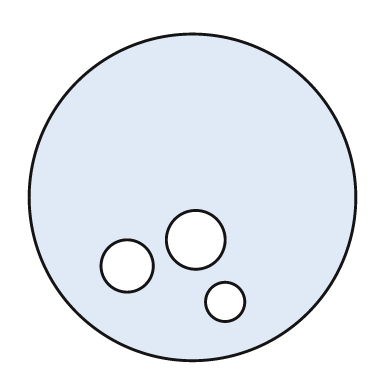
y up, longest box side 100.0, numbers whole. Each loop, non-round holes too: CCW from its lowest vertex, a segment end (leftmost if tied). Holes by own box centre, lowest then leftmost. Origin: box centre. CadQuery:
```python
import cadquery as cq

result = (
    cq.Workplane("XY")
    .moveTo(0.0, 0.0)
    .circle(50.0)
    .moveTo(10.0, -32.0)
    .circle(6.0)
    .moveTo(-20.0, -21.0)
    .circle(8.0)
    .moveTo(1.0, -13.0)
    .circle(9.0)
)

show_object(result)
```